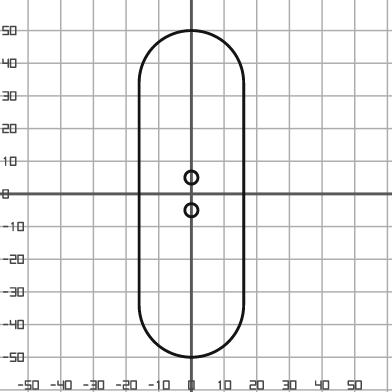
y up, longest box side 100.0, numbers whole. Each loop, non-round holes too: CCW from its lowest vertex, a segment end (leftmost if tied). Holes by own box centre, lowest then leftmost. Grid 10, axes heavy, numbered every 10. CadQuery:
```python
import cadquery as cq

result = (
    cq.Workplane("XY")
    .moveTo(-16.0, -34.0)
    .threePointArc((0.0, -50.0), (16.0, -34.0))
    .lineTo(16.0, 34.0)
    .threePointArc((0.0, 50.0), (-16.0, 34.0))
    .close()
    .moveTo(0.0, -5.0)
    .circle(2.0)
    .moveTo(0.0, 5.0)
    .circle(2.0)
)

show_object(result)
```